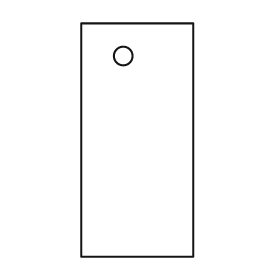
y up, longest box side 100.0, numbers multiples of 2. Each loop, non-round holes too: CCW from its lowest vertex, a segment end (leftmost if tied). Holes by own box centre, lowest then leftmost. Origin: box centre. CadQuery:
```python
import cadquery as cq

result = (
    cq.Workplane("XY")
    .moveTo(-24.0, -50.0)
    .lineTo(24.0, -50.0)
    .lineTo(24.0, 50.0)
    .lineTo(-24.0, 50.0)
    .close()
    .moveTo(-6.0, 36.0)
    .circle(4.0)
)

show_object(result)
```